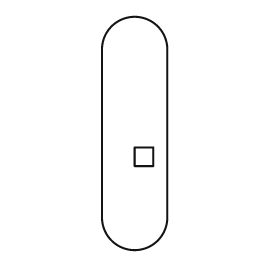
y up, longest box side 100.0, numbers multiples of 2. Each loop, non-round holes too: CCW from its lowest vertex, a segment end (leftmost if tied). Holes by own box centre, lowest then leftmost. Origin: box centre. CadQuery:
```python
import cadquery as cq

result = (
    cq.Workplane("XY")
    .moveTo(-14.0, -36.0)
    .threePointArc((0.0, -50.0), (14.0, -36.0))
    .lineTo(14.0, 36.0)
    .threePointArc((0.0, 50.0), (-14.0, 36.0))
    .close()
    .moveTo(0.0, -14.0)
    .lineTo(8.0, -14.0)
    .lineTo(8.0, -6.0)
    .lineTo(0.0, -6.0)
    .close()
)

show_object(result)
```